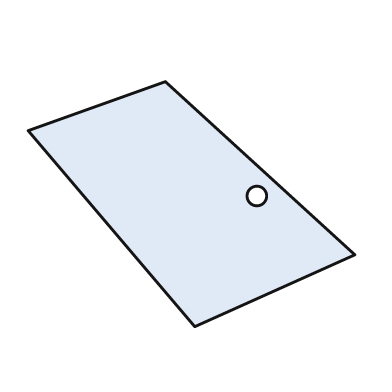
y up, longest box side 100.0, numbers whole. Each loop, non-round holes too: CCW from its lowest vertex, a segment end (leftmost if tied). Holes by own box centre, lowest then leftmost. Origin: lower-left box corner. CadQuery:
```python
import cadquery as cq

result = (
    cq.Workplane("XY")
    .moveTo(51.0, 0.0)
    .lineTo(100.0, 22.0)
    .lineTo(42.0, 75.0)
    .lineTo(0.0, 60.0)
    .close()
    .moveTo(70.0, 40.0)
    .circle(3.0)
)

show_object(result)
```